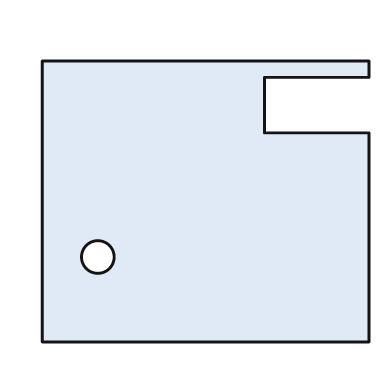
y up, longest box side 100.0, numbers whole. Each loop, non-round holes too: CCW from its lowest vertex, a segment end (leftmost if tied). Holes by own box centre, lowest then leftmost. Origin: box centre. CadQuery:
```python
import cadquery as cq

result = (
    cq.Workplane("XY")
    .moveTo(-50.0, -43.0)
    .lineTo(50.0, -43.0)
    .lineTo(50.0, 21.0)
    .lineTo(18.0, 21.0)
    .lineTo(18.0, 38.0)
    .lineTo(50.0, 38.0)
    .lineTo(50.0, 43.0)
    .lineTo(-50.0, 43.0)
    .close()
    .moveTo(-33.0, -17.0)
    .circle(5.0)
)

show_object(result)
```